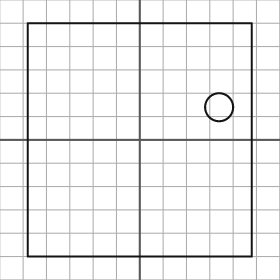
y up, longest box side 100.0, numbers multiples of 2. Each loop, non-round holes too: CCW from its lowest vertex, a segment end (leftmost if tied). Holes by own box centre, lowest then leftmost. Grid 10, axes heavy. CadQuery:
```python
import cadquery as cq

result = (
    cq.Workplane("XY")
    .moveTo(-48.0, -50.0)
    .lineTo(48.0, -50.0)
    .lineTo(48.0, 50.0)
    .lineTo(-48.0, 50.0)
    .close()
    .moveTo(34.0, 14.0)
    .circle(6.0)
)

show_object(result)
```